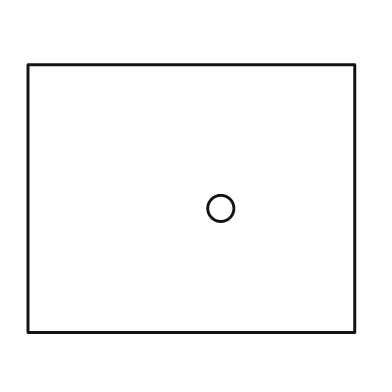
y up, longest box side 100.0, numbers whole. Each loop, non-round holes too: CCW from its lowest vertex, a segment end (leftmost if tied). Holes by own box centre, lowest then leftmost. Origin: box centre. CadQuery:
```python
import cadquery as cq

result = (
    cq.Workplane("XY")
    .moveTo(-50.0, -41.0)
    .lineTo(50.0, -41.0)
    .lineTo(50.0, 41.0)
    .lineTo(-50.0, 41.0)
    .close()
    .moveTo(9.0, -3.0)
    .circle(4.0)
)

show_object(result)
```